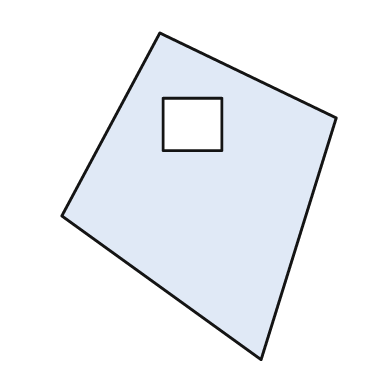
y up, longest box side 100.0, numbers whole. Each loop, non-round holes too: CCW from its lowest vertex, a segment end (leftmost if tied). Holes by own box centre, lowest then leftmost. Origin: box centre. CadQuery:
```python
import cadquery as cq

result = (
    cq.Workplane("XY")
    .moveTo(19.0, -50.0)
    .lineTo(42.0, 24.0)
    .lineTo(-12.0, 50.0)
    .lineTo(-42.0, -6.0)
    .close()
    .moveTo(-11.0, 14.0)
    .lineTo(7.0, 14.0)
    .lineTo(7.0, 30.0)
    .lineTo(-11.0, 30.0)
    .close()
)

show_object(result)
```